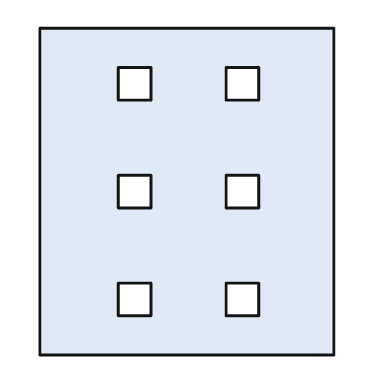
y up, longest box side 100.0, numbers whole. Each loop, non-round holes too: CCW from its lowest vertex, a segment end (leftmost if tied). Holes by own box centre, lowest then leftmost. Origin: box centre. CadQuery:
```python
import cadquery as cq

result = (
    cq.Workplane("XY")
    .moveTo(-45.0, -50.0)
    .lineTo(45.0, -50.0)
    .lineTo(45.0, 50.0)
    .lineTo(-45.0, 50.0)
    .close()
    .moveTo(-21.0, -38.0)
    .lineTo(-11.0, -38.0)
    .lineTo(-11.0, -28.0)
    .lineTo(-21.0, -28.0)
    .close()
    .moveTo(12.0, -38.0)
    .lineTo(22.0, -38.0)
    .lineTo(22.0, -28.0)
    .lineTo(12.0, -28.0)
    .close()
    .moveTo(-21.0, -5.0)
    .lineTo(-11.0, -5.0)
    .lineTo(-11.0, 5.0)
    .lineTo(-21.0, 5.0)
    .close()
    .moveTo(12.0, -5.0)
    .lineTo(22.0, -5.0)
    .lineTo(22.0, 5.0)
    .lineTo(12.0, 5.0)
    .close()
    .moveTo(-21.0, 28.0)
    .lineTo(-11.0, 28.0)
    .lineTo(-11.0, 38.0)
    .lineTo(-21.0, 38.0)
    .close()
    .moveTo(12.0, 28.0)
    .lineTo(22.0, 28.0)
    .lineTo(22.0, 38.0)
    .lineTo(12.0, 38.0)
    .close()
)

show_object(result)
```